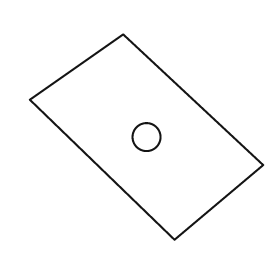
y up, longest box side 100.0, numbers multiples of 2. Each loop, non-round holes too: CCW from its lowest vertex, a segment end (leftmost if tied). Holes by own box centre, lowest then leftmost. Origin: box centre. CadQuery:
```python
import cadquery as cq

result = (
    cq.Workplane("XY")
    .moveTo(12.0, -44.0)
    .lineTo(50.0, -12.0)
    .lineTo(-10.0, 44.0)
    .lineTo(-50.0, 16.0)
    .close()
    .moveTo(0.0, 0.0)
    .circle(6.0)
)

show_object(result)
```